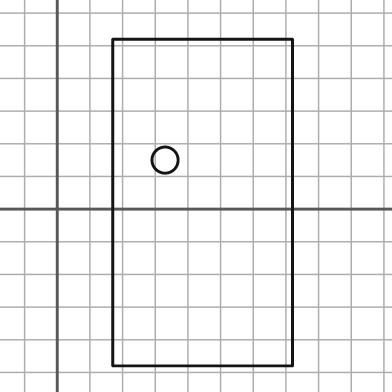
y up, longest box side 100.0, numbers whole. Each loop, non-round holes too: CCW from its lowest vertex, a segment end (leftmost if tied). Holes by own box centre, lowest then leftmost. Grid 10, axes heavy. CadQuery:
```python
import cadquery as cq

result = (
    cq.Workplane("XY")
    .moveTo(17.0, -48.0)
    .lineTo(72.0, -48.0)
    .lineTo(72.0, 52.0)
    .lineTo(17.0, 52.0)
    .close()
    .moveTo(33.0, 15.0)
    .circle(4.0)
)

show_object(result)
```